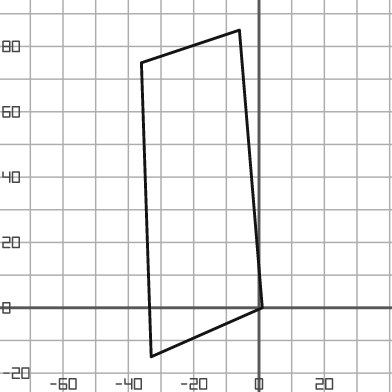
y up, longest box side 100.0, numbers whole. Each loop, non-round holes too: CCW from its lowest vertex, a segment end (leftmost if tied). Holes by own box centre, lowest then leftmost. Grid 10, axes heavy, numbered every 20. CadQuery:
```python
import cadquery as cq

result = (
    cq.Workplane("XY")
    .moveTo(-33.0, -15.0)
    .lineTo(1.0, 0.0)
    .lineTo(-6.0, 85.0)
    .lineTo(-36.0, 75.0)
    .close()
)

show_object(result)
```